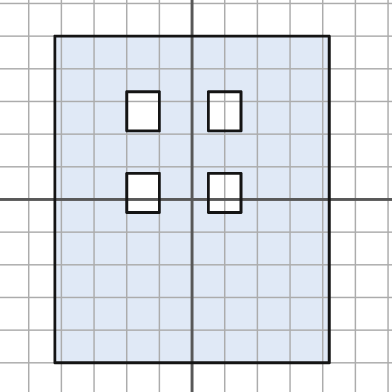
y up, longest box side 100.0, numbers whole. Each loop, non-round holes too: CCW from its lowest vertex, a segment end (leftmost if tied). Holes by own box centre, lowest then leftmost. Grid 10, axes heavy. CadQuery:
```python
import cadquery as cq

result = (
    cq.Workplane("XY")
    .moveTo(-42.0, -50.0)
    .lineTo(42.0, -50.0)
    .lineTo(42.0, 50.0)
    .lineTo(-42.0, 50.0)
    .close()
    .moveTo(-20.0, -4.0)
    .lineTo(-10.0, -4.0)
    .lineTo(-10.0, 8.0)
    .lineTo(-20.0, 8.0)
    .close()
    .moveTo(5.0, -4.0)
    .lineTo(15.0, -4.0)
    .lineTo(15.0, 8.0)
    .lineTo(5.0, 8.0)
    .close()
    .moveTo(-20.0, 21.0)
    .lineTo(-10.0, 21.0)
    .lineTo(-10.0, 33.0)
    .lineTo(-20.0, 33.0)
    .close()
    .moveTo(5.0, 21.0)
    .lineTo(15.0, 21.0)
    .lineTo(15.0, 33.0)
    .lineTo(5.0, 33.0)
    .close()
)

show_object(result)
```